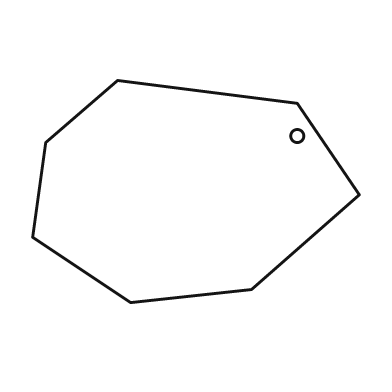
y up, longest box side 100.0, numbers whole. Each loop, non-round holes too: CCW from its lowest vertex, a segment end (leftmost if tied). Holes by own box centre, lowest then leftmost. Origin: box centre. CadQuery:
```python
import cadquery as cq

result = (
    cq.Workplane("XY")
    .moveTo(-20.0, -34.0)
    .lineTo(17.0, -30.0)
    .lineTo(50.0, -1.0)
    .lineTo(31.0, 27.0)
    .lineTo(-24.0, 34.0)
    .lineTo(-46.0, 15.0)
    .lineTo(-50.0, -14.0)
    .close()
    .moveTo(31.0, 17.0)
    .circle(2.0)
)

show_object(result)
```